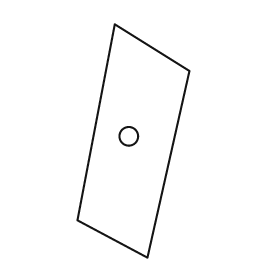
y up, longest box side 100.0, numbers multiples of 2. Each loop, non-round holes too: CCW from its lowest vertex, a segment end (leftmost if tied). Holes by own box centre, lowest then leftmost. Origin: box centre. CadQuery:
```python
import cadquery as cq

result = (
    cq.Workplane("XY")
    .moveTo(6.0, -50.0)
    .lineTo(24.0, 30.0)
    .lineTo(-8.0, 50.0)
    .lineTo(-24.0, -34.0)
    .close()
    .moveTo(-2.0, 2.0)
    .circle(4.0)
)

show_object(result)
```